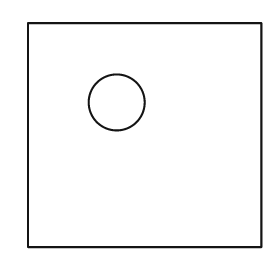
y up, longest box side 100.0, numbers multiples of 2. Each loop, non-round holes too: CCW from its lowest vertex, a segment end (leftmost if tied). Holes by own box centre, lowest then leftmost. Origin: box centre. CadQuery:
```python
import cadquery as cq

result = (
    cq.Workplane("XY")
    .moveTo(-50.0, -48.0)
    .lineTo(50.0, -48.0)
    .lineTo(50.0, 48.0)
    .lineTo(-50.0, 48.0)
    .close()
    .moveTo(-12.0, 14.0)
    .circle(12.0)
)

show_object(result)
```